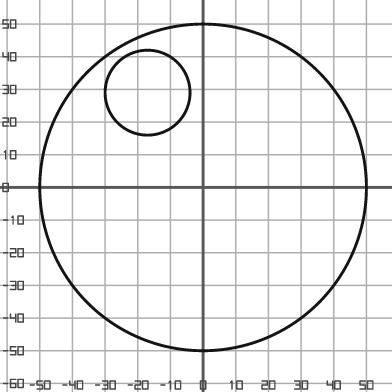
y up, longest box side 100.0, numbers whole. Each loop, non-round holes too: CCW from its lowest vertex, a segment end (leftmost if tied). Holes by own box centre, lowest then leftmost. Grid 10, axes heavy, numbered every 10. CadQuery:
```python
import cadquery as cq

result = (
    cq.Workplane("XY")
    .moveTo(0.0, 0.0)
    .circle(50.0)
    .moveTo(-17.0, 29.0)
    .circle(13.0)
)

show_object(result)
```